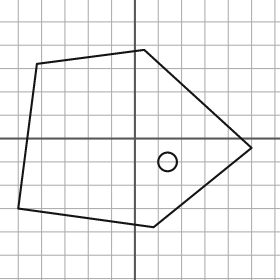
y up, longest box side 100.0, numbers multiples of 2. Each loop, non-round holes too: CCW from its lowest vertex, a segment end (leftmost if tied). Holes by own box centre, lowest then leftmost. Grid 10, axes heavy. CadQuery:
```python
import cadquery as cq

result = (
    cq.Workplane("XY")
    .moveTo(8.0, -38.0)
    .lineTo(50.0, -4.0)
    .lineTo(4.0, 38.0)
    .lineTo(-42.0, 32.0)
    .lineTo(-50.0, -30.0)
    .close()
    .moveTo(14.0, -10.0)
    .circle(4.0)
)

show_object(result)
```